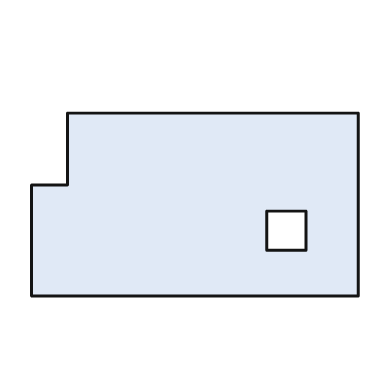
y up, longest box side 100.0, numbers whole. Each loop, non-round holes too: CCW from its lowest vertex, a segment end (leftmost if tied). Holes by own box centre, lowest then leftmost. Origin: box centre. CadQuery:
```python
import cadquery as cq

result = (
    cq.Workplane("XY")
    .moveTo(-50.0, -28.0)
    .lineTo(50.0, -28.0)
    .lineTo(50.0, 28.0)
    .lineTo(-39.0, 28.0)
    .lineTo(-39.0, 6.0)
    .lineTo(-50.0, 6.0)
    .close()
    .moveTo(22.0, -14.0)
    .lineTo(34.0, -14.0)
    .lineTo(34.0, -2.0)
    .lineTo(22.0, -2.0)
    .close()
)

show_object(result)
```